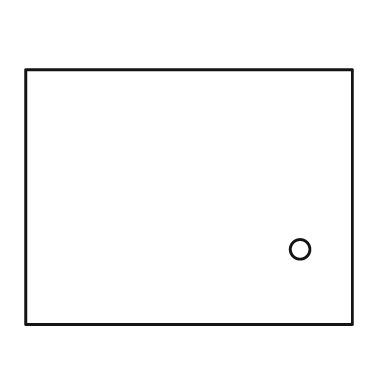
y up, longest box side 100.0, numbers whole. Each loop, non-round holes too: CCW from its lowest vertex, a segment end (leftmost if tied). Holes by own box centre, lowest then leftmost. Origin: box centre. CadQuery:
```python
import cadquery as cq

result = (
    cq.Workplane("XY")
    .moveTo(-50.0, -39.0)
    .lineTo(50.0, -39.0)
    .lineTo(50.0, 39.0)
    .lineTo(-50.0, 39.0)
    .close()
    .moveTo(34.0, -16.0)
    .circle(3.0)
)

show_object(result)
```